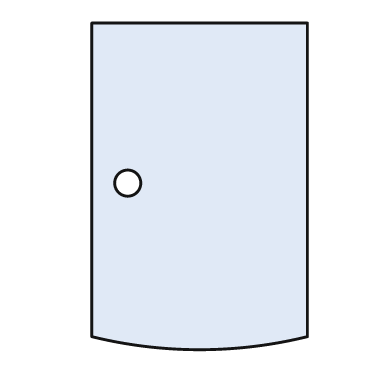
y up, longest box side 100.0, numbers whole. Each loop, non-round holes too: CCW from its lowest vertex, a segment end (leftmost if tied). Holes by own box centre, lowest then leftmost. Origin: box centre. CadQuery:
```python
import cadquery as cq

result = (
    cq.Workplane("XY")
    .moveTo(-33.0, -46.0)
    .threePointArc((0.0, -50.0), (33.0, -46.0))
    .lineTo(33.0, 50.0)
    .lineTo(-33.0, 50.0)
    .close()
    .moveTo(-22.0, 1.0)
    .circle(4.0)
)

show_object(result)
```